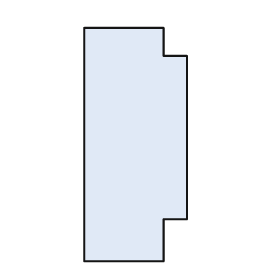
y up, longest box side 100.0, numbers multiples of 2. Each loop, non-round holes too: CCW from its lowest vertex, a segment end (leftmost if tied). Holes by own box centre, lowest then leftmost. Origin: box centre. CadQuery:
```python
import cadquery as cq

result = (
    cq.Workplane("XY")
    .moveTo(-22.0, -50.0)
    .lineTo(12.0, -50.0)
    .lineTo(12.0, -32.0)
    .lineTo(22.0, -32.0)
    .lineTo(22.0, 38.0)
    .lineTo(12.0, 38.0)
    .lineTo(12.0, 50.0)
    .lineTo(-22.0, 50.0)
    .close()
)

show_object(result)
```